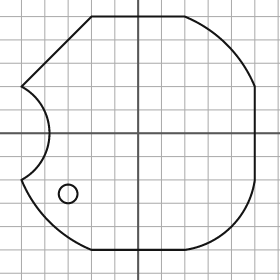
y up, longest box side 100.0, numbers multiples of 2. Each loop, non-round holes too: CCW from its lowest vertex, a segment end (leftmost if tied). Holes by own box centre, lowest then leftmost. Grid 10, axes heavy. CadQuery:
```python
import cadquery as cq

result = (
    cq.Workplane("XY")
    .moveTo(-20.0, -50.0)
    .lineTo(20.0, -50.0)
    .threePointArc((40.0, -40.0), (50.0, -20.0))
    .lineTo(50.0, 20.0)
    .threePointArc((38.0, 38.0), (20.0, 50.0))
    .lineTo(-20.0, 50.0)
    .lineTo(-50.0, 20.0)
    .threePointArc((-38.0, 0.0), (-50.0, -20.0))
    .threePointArc((-38.0, -38.0), (-20.0, -50.0))
    .close()
    .moveTo(-30.0, -26.0)
    .circle(4.0)
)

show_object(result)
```